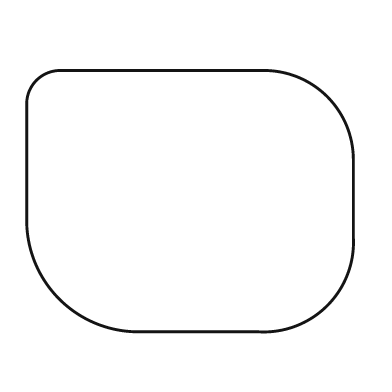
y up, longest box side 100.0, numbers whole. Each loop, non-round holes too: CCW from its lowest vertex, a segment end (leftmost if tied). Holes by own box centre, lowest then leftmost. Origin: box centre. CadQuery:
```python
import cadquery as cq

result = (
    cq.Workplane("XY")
    .moveTo(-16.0, -40.0)
    .lineTo(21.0, -40.0)
    .threePointArc((42.0, -32.0), (50.0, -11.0))
    .lineTo(50.0, 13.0)
    .threePointArc((42.0, 32.0), (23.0, 40.0))
    .lineTo(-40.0, 40.0)
    .threePointArc((-47.0, 37.0), (-50.0, 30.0))
    .lineTo(-50.0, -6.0)
    .threePointArc((-40.0, -30.0), (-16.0, -40.0))
    .close()
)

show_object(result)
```